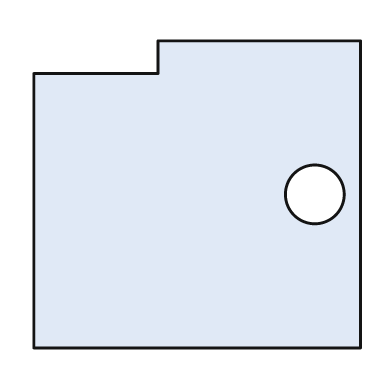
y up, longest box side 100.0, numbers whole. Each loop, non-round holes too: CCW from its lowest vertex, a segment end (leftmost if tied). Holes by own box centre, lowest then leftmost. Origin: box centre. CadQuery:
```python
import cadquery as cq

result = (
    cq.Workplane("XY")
    .moveTo(-50.0, -47.0)
    .lineTo(50.0, -47.0)
    .lineTo(50.0, 47.0)
    .lineTo(-12.0, 47.0)
    .lineTo(-12.0, 37.0)
    .lineTo(-50.0, 37.0)
    .close()
    .moveTo(36.0, 0.0)
    .circle(9.0)
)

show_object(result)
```